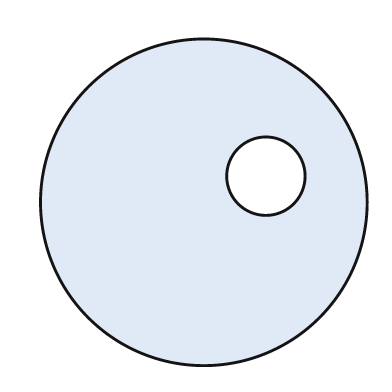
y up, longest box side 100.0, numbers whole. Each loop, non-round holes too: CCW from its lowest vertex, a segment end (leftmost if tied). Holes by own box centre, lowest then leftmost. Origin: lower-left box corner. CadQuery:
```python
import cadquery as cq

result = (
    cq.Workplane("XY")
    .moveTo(50.0, 50.0)
    .circle(50.0)
    .moveTo(69.0, 58.0)
    .circle(12.0)
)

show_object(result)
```